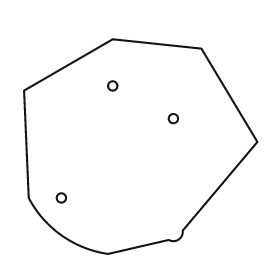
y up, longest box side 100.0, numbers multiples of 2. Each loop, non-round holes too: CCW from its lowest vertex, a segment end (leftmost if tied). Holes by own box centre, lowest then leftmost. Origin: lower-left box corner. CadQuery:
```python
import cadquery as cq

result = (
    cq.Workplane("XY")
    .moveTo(36.0, 0.0)
    .lineTo(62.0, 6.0)
    .threePointArc((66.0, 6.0), (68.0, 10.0))
    .lineTo(100.0, 48.0)
    .lineTo(76.0, 88.0)
    .lineTo(38.0, 92.0)
    .lineTo(0.0, 70.0)
    .lineTo(2.0, 24.0)
    .threePointArc((16.0, 8.0), (36.0, 0.0))
    .close()
    .moveTo(16.0, 24.0)
    .circle(2.0)
    .moveTo(64.0, 58.0)
    .circle(2.0)
    .moveTo(38.0, 72.0)
    .circle(2.0)
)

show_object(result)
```